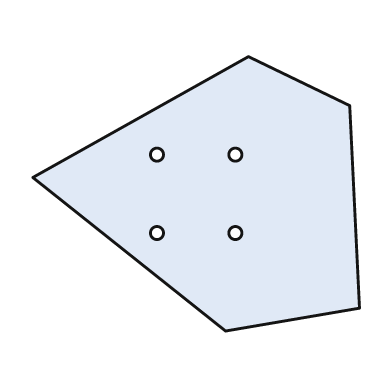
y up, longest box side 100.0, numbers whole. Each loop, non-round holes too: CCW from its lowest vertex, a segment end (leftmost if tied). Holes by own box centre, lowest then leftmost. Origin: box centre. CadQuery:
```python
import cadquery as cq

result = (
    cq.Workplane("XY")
    .moveTo(9.0, -42.0)
    .lineTo(50.0, -35.0)
    .lineTo(47.0, 27.0)
    .lineTo(16.0, 42.0)
    .lineTo(-50.0, 5.0)
    .close()
    .moveTo(-12.0, -12.0)
    .circle(2.0)
    .moveTo(12.0, -12.0)
    .circle(2.0)
    .moveTo(-12.0, 12.0)
    .circle(2.0)
    .moveTo(12.0, 12.0)
    .circle(2.0)
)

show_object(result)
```